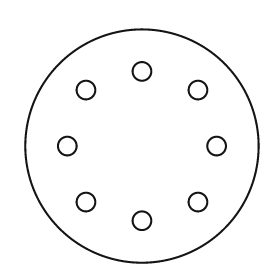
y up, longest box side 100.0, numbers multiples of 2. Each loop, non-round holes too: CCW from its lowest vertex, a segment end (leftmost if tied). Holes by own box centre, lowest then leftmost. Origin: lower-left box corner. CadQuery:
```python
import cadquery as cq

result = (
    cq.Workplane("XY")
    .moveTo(50.0, 50.0)
    .circle(50.0)
    .moveTo(50.0, 18.0)
    .circle(4.0)
    .moveTo(26.0, 26.0)
    .circle(4.0)
    .moveTo(74.0, 26.0)
    .circle(4.0)
    .moveTo(18.0, 50.0)
    .circle(4.0)
    .moveTo(82.0, 50.0)
    .circle(4.0)
    .moveTo(26.0, 74.0)
    .circle(4.0)
    .moveTo(74.0, 74.0)
    .circle(4.0)
    .moveTo(50.0, 82.0)
    .circle(4.0)
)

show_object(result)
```